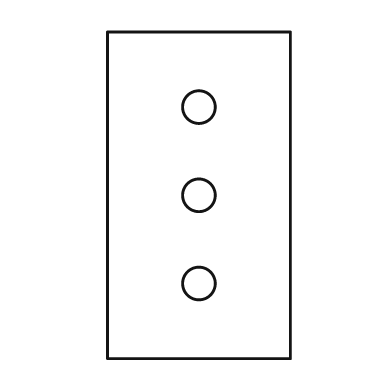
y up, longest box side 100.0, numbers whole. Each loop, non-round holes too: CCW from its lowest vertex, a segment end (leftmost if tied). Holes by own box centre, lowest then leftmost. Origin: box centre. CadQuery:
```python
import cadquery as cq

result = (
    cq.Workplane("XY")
    .moveTo(-28.0, -50.0)
    .lineTo(28.0, -50.0)
    .lineTo(28.0, 50.0)
    .lineTo(-28.0, 50.0)
    .close()
    .moveTo(0.0, -27.0)
    .circle(5.0)
    .moveTo(0.0, 0.0)
    .circle(5.0)
    .moveTo(0.0, 27.0)
    .circle(5.0)
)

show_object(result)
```